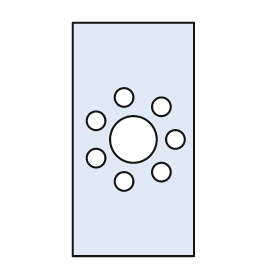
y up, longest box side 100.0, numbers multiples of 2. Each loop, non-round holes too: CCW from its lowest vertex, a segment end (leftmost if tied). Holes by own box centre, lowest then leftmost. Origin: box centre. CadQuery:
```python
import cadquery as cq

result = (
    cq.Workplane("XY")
    .moveTo(-26.0, -50.0)
    .lineTo(26.0, -50.0)
    .lineTo(26.0, 50.0)
    .lineTo(-26.0, 50.0)
    .close()
    .moveTo(-4.0, -18.0)
    .circle(4.0)
    .moveTo(12.0, -14.0)
    .circle(4.0)
    .moveTo(-16.0, -8.0)
    .circle(4.0)
    .moveTo(0.0, 0.0)
    .circle(10.0)
    .moveTo(18.0, 0.0)
    .circle(4.0)
    .moveTo(-16.0, 8.0)
    .circle(4.0)
    .moveTo(12.0, 14.0)
    .circle(4.0)
    .moveTo(-4.0, 18.0)
    .circle(4.0)
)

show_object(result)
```